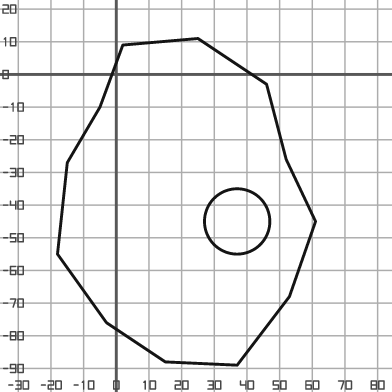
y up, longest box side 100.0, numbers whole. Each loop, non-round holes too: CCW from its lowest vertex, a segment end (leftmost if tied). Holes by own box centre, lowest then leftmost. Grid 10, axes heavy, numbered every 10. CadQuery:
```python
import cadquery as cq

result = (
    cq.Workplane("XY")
    .moveTo(37.0, -89.0)
    .lineTo(53.0, -68.0)
    .lineTo(61.0, -45.0)
    .lineTo(52.0, -26.0)
    .lineTo(46.0, -3.0)
    .lineTo(25.0, 11.0)
    .lineTo(2.0, 9.0)
    .lineTo(-5.0, -10.0)
    .lineTo(-15.0, -27.0)
    .lineTo(-18.0, -55.0)
    .lineTo(-3.0, -76.0)
    .lineTo(15.0, -88.0)
    .close()
    .moveTo(37.0, -45.0)
    .circle(10.0)
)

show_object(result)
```